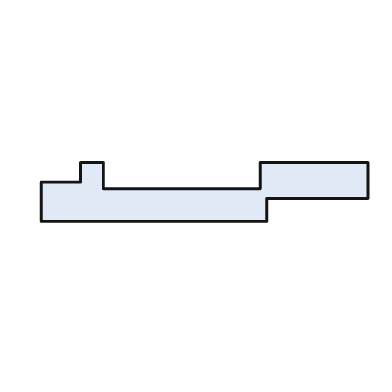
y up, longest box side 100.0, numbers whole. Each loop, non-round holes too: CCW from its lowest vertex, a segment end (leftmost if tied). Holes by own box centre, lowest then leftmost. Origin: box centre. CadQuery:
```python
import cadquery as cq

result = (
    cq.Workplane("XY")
    .moveTo(-50.0, -9.0)
    .lineTo(19.0, -9.0)
    .lineTo(19.0, -2.0)
    .lineTo(50.0, -2.0)
    .lineTo(50.0, 9.0)
    .lineTo(17.0, 9.0)
    .lineTo(17.0, 1.0)
    .lineTo(-31.0, 1.0)
    .lineTo(-31.0, 9.0)
    .lineTo(-38.0, 9.0)
    .lineTo(-38.0, 3.0)
    .lineTo(-50.0, 3.0)
    .close()
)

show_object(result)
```